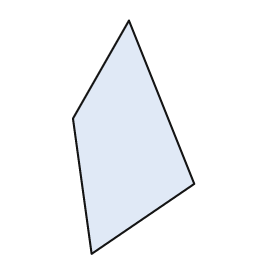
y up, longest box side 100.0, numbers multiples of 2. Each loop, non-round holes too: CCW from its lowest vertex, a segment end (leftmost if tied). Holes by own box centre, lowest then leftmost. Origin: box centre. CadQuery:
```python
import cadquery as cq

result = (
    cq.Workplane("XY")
    .moveTo(-18.0, -50.0)
    .lineTo(26.0, -20.0)
    .lineTo(-2.0, 50.0)
    .lineTo(-26.0, 8.0)
    .close()
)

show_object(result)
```